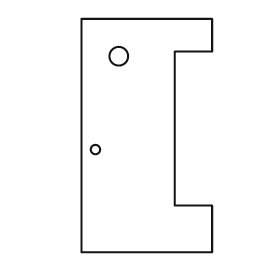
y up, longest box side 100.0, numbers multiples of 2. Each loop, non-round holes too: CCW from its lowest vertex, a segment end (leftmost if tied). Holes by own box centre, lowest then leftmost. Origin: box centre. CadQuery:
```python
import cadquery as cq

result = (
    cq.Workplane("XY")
    .moveTo(-28.0, -50.0)
    .lineTo(28.0, -50.0)
    .lineTo(28.0, -30.0)
    .lineTo(12.0, -30.0)
    .lineTo(12.0, 36.0)
    .lineTo(28.0, 36.0)
    .lineTo(28.0, 50.0)
    .lineTo(-28.0, 50.0)
    .close()
    .moveTo(-22.0, -6.0)
    .circle(2.0)
    .moveTo(-12.0, 34.0)
    .circle(4.0)
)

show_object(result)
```